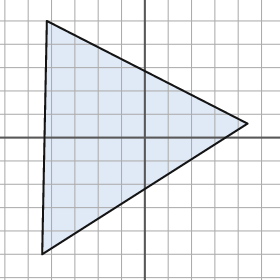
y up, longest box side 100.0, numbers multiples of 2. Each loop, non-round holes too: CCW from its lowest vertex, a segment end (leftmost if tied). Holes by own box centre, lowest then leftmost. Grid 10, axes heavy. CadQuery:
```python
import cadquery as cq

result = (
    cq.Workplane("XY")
    .moveTo(-44.0, -50.0)
    .lineTo(44.0, 6.0)
    .lineTo(-42.0, 50.0)
    .close()
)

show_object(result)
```